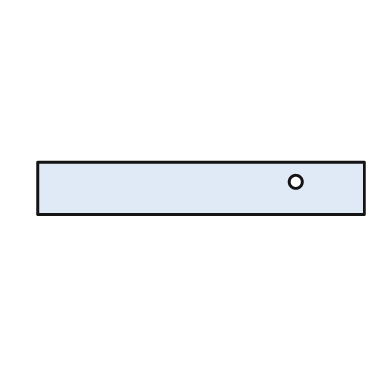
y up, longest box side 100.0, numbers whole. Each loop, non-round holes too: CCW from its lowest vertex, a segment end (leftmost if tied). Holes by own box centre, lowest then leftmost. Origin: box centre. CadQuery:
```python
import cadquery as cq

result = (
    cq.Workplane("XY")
    .moveTo(-50.0, -8.0)
    .lineTo(50.0, -8.0)
    .lineTo(50.0, 8.0)
    .lineTo(-50.0, 8.0)
    .close()
    .moveTo(29.0, 2.0)
    .circle(2.0)
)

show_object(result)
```